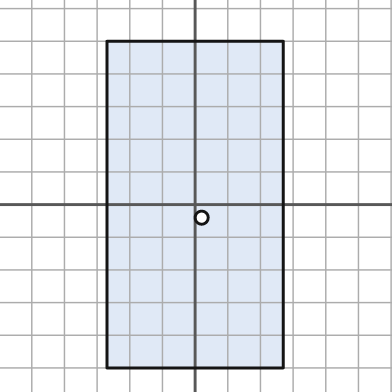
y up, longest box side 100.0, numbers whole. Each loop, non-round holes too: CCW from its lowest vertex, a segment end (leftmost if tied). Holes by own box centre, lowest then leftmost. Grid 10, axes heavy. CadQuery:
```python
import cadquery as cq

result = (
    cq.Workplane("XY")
    .moveTo(-27.0, -50.0)
    .lineTo(27.0, -50.0)
    .lineTo(27.0, 50.0)
    .lineTo(-27.0, 50.0)
    .close()
    .moveTo(2.0, -4.0)
    .circle(2.0)
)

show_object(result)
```